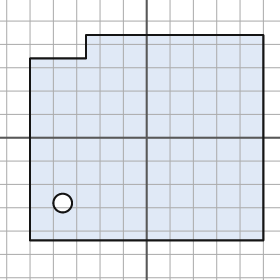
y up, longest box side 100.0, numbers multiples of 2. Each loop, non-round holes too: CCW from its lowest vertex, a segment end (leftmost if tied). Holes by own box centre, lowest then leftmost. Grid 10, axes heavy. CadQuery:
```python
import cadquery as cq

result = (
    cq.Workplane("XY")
    .moveTo(-50.0, -44.0)
    .lineTo(50.0, -44.0)
    .lineTo(50.0, 44.0)
    .lineTo(-26.0, 44.0)
    .lineTo(-26.0, 34.0)
    .lineTo(-50.0, 34.0)
    .close()
    .moveTo(-36.0, -28.0)
    .circle(4.0)
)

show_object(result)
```